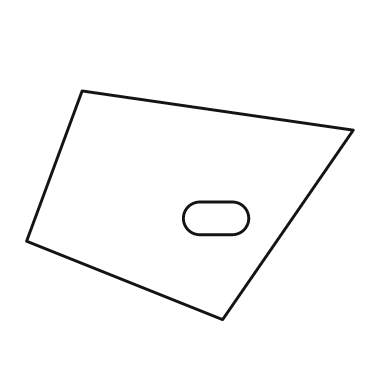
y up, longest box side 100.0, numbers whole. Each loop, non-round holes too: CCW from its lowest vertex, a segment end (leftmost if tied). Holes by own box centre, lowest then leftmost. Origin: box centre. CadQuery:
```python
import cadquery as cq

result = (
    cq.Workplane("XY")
    .moveTo(10.0, -35.0)
    .lineTo(50.0, 23.0)
    .lineTo(-33.0, 35.0)
    .lineTo(-50.0, -11.0)
    .close()
    .moveTo(3.0, -9.0)
    .lineTo(13.0, -9.0)
    .threePointArc((18.0, -4.0), (13.0, 1.0))
    .lineTo(3.0, 1.0)
    .threePointArc((-2.0, -4.0), (3.0, -9.0))
    .close()
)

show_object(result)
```